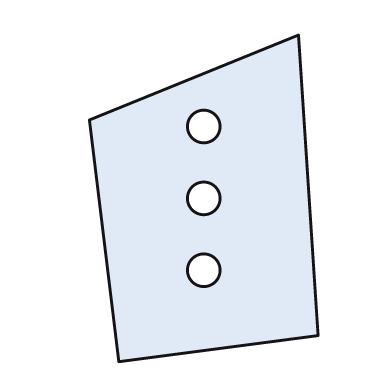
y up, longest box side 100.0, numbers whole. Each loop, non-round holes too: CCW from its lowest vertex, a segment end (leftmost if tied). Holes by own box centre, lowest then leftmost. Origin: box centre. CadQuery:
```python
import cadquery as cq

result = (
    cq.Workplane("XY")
    .moveTo(-26.0, -50.0)
    .lineTo(35.0, -42.0)
    .lineTo(29.0, 50.0)
    .lineTo(-35.0, 24.0)
    .close()
    .moveTo(0.0, -22.0)
    .circle(5.0)
    .moveTo(0.0, 0.0)
    .circle(5.0)
    .moveTo(0.0, 22.0)
    .circle(5.0)
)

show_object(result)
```